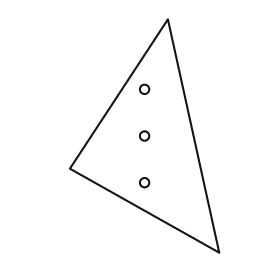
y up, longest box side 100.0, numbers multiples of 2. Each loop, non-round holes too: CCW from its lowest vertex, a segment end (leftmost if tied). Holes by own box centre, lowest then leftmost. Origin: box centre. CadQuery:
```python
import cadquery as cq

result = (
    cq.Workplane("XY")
    .moveTo(32.0, -50.0)
    .lineTo(10.0, 50.0)
    .lineTo(-32.0, -14.0)
    .close()
    .moveTo(0.0, -20.0)
    .circle(2.0)
    .moveTo(0.0, 0.0)
    .circle(2.0)
    .moveTo(0.0, 20.0)
    .circle(2.0)
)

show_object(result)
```